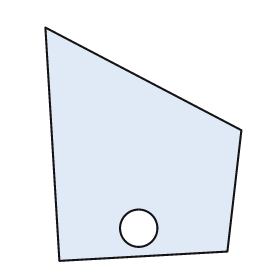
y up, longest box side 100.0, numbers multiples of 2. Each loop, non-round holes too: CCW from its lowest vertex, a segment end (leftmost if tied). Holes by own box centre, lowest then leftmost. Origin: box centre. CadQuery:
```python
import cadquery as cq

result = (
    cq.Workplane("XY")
    .moveTo(-36.0, -50.0)
    .lineTo(36.0, -46.0)
    .lineTo(42.0, 6.0)
    .lineTo(-42.0, 50.0)
    .close()
    .moveTo(-2.0, -36.0)
    .circle(8.0)
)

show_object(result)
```